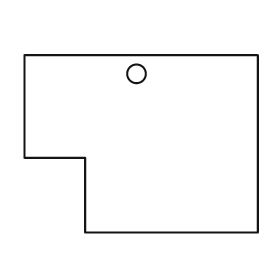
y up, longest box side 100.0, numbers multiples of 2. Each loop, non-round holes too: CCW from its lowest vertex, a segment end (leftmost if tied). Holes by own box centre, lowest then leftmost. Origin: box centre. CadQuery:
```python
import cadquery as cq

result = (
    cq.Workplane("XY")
    .moveTo(-24.0, -38.0)
    .lineTo(50.0, -38.0)
    .lineTo(50.0, 38.0)
    .lineTo(-50.0, 38.0)
    .lineTo(-50.0, -6.0)
    .lineTo(-24.0, -6.0)
    .close()
    .moveTo(-2.0, 30.0)
    .circle(4.0)
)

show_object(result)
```